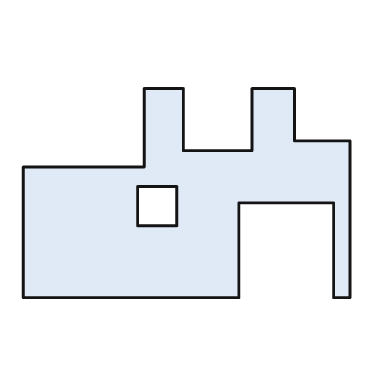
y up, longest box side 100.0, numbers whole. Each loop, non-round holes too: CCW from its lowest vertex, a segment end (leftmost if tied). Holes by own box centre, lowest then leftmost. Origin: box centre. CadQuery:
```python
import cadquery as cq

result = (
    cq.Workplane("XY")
    .moveTo(-50.0, -32.0)
    .lineTo(16.0, -32.0)
    .lineTo(16.0, -3.0)
    .lineTo(45.0, -3.0)
    .lineTo(45.0, -32.0)
    .lineTo(50.0, -32.0)
    .lineTo(50.0, 16.0)
    .lineTo(33.0, 16.0)
    .lineTo(33.0, 32.0)
    .lineTo(20.0, 32.0)
    .lineTo(20.0, 13.0)
    .lineTo(-1.0, 13.0)
    .lineTo(-1.0, 32.0)
    .lineTo(-13.0, 32.0)
    .lineTo(-13.0, 8.0)
    .lineTo(-50.0, 8.0)
    .close()
    .moveTo(-15.0, -10.0)
    .lineTo(-3.0, -10.0)
    .lineTo(-3.0, 2.0)
    .lineTo(-15.0, 2.0)
    .close()
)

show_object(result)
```